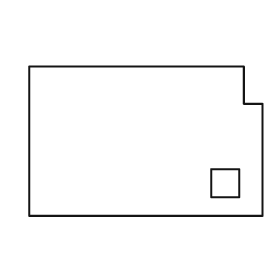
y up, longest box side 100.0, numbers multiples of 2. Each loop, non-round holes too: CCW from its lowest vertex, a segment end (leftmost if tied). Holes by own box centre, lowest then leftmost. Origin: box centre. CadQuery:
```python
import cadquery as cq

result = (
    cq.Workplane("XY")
    .moveTo(-50.0, -32.0)
    .lineTo(50.0, -32.0)
    .lineTo(50.0, 16.0)
    .lineTo(42.0, 16.0)
    .lineTo(42.0, 32.0)
    .lineTo(-50.0, 32.0)
    .close()
    .moveTo(28.0, -24.0)
    .lineTo(40.0, -24.0)
    .lineTo(40.0, -12.0)
    .lineTo(28.0, -12.0)
    .close()
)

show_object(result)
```